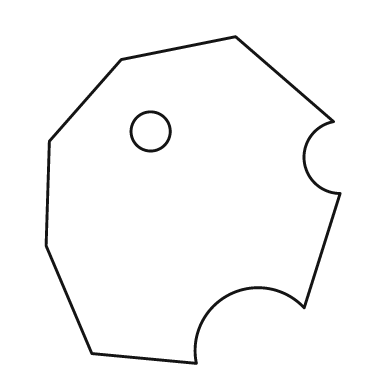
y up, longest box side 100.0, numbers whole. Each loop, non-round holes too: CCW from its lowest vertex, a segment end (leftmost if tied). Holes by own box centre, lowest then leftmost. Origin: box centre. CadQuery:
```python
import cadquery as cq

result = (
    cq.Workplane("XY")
    .moveTo(1.0, -50.0)
    .threePointArc((11.0, -29.0), (34.0, -33.0))
    .lineTo(45.0, 2.0)
    .threePointArc((34.0, 12.0), (43.0, 24.0))
    .lineTo(13.0, 50.0)
    .lineTo(-22.0, 43.0)
    .lineTo(-44.0, 18.0)
    .lineTo(-45.0, -14.0)
    .lineTo(-31.0, -47.0)
    .close()
    .moveTo(-13.0, 21.0)
    .circle(6.0)
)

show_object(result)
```